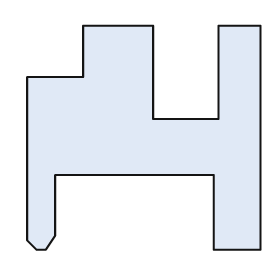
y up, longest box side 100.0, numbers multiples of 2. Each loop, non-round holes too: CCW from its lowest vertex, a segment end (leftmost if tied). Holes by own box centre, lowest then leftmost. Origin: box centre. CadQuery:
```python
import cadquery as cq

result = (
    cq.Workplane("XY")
    .moveTo(-46.0, -48.0)
    .lineTo(-42.0, -48.0)
    .lineTo(-38.0, -42.0)
    .lineTo(-38.0, -16.0)
    .lineTo(30.0, -16.0)
    .lineTo(30.0, -48.0)
    .lineTo(50.0, -48.0)
    .lineTo(50.0, 48.0)
    .lineTo(32.0, 48.0)
    .lineTo(32.0, 8.0)
    .lineTo(4.0, 8.0)
    .lineTo(4.0, 48.0)
    .lineTo(-26.0, 48.0)
    .lineTo(-26.0, 26.0)
    .lineTo(-50.0, 26.0)
    .lineTo(-50.0, -44.0)
    .close()
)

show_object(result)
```